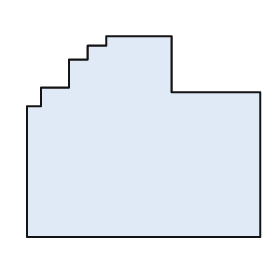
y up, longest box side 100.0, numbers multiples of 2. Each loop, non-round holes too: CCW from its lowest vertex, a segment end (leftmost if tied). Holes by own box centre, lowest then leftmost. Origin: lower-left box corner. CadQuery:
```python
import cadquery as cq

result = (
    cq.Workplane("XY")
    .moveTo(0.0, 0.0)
    .lineTo(100.0, 0.0)
    .lineTo(100.0, 62.0)
    .lineTo(62.0, 62.0)
    .lineTo(62.0, 86.0)
    .lineTo(34.0, 86.0)
    .lineTo(34.0, 82.0)
    .lineTo(26.0, 82.0)
    .lineTo(26.0, 76.0)
    .lineTo(18.0, 76.0)
    .lineTo(18.0, 64.0)
    .lineTo(6.0, 64.0)
    .lineTo(6.0, 56.0)
    .lineTo(0.0, 56.0)
    .close()
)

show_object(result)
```